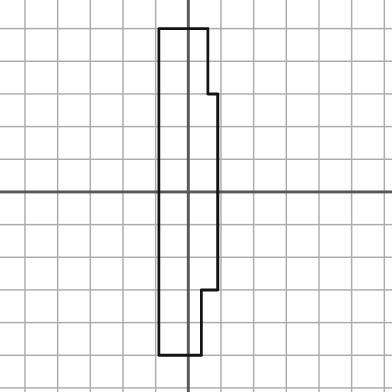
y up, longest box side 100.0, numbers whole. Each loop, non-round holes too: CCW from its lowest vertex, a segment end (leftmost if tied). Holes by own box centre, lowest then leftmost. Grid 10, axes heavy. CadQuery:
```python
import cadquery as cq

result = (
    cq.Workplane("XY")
    .moveTo(-9.0, -50.0)
    .lineTo(4.0, -50.0)
    .lineTo(4.0, -30.0)
    .lineTo(9.0, -30.0)
    .lineTo(9.0, 30.0)
    .lineTo(6.0, 30.0)
    .lineTo(6.0, 50.0)
    .lineTo(-9.0, 50.0)
    .close()
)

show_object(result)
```